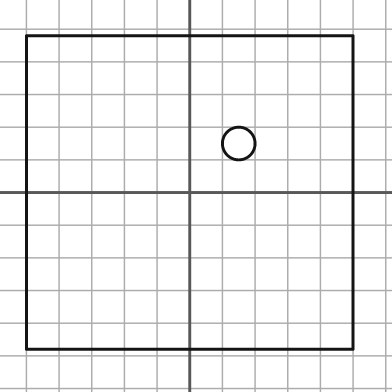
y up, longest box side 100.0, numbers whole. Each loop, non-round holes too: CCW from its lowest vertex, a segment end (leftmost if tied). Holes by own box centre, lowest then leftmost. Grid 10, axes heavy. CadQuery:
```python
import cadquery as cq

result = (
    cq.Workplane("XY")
    .moveTo(-50.0, -48.0)
    .lineTo(50.0, -48.0)
    .lineTo(50.0, 48.0)
    .lineTo(-50.0, 48.0)
    .close()
    .moveTo(15.0, 15.0)
    .circle(5.0)
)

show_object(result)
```